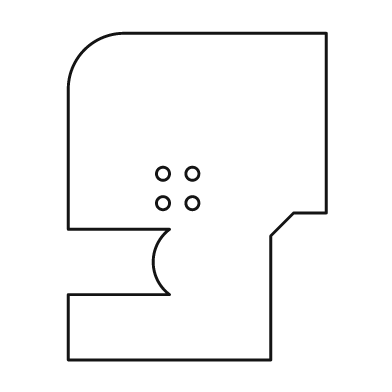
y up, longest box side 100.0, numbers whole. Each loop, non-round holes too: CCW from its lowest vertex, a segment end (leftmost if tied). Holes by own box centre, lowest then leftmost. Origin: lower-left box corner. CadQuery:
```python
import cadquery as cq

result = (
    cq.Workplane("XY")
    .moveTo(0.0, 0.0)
    .lineTo(62.0, 0.0)
    .lineTo(62.0, 38.0)
    .lineTo(69.0, 45.0)
    .lineTo(79.0, 45.0)
    .lineTo(79.0, 100.0)
    .lineTo(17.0, 100.0)
    .threePointArc((5.0, 95.0), (0.0, 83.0))
    .lineTo(0.0, 40.0)
    .lineTo(31.0, 40.0)
    .threePointArc((26.0, 30.0), (31.0, 20.0))
    .lineTo(0.0, 20.0)
    .close()
    .moveTo(29.0, 48.0)
    .circle(2.0)
    .moveTo(38.0, 48.0)
    .circle(2.0)
    .moveTo(29.0, 57.0)
    .circle(2.0)
    .moveTo(38.0, 57.0)
    .circle(2.0)
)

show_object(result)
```